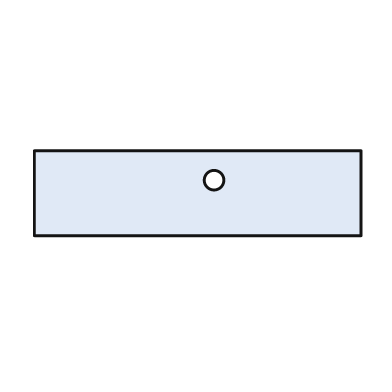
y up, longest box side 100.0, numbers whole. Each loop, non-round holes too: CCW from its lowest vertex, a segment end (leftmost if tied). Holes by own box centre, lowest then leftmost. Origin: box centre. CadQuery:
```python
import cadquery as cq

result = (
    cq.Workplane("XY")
    .moveTo(-50.0, -13.0)
    .lineTo(50.0, -13.0)
    .lineTo(50.0, 13.0)
    .lineTo(-50.0, 13.0)
    .close()
    .moveTo(5.0, 4.0)
    .circle(3.0)
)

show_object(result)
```